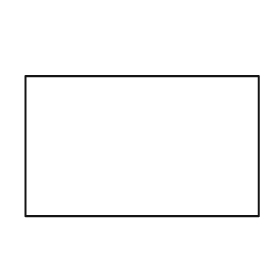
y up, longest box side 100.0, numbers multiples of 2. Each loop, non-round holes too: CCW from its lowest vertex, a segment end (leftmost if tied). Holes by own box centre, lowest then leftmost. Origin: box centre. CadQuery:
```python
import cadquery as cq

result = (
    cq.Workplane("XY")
    .moveTo(-50.0, -30.0)
    .lineTo(50.0, -30.0)
    .lineTo(50.0, 30.0)
    .lineTo(-50.0, 30.0)
    .close()
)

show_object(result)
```